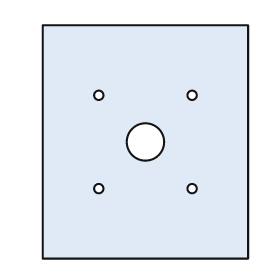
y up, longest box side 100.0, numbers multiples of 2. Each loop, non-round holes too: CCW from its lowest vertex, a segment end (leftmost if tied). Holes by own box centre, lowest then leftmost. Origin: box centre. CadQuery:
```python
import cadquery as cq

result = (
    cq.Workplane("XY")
    .moveTo(-44.0, -50.0)
    .lineTo(44.0, -50.0)
    .lineTo(44.0, 50.0)
    .lineTo(-44.0, 50.0)
    .close()
    .moveTo(-20.0, -20.0)
    .circle(2.0)
    .moveTo(20.0, -20.0)
    .circle(2.0)
    .moveTo(0.0, 0.0)
    .circle(8.0)
    .moveTo(-20.0, 20.0)
    .circle(2.0)
    .moveTo(20.0, 20.0)
    .circle(2.0)
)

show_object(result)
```